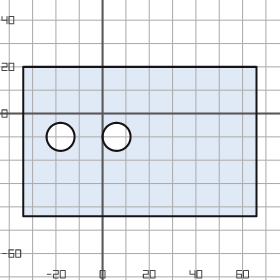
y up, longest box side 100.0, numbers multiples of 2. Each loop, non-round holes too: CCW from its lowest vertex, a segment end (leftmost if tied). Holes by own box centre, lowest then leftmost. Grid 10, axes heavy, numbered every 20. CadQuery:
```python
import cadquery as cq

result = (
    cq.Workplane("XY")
    .moveTo(-34.0, -44.0)
    .lineTo(66.0, -44.0)
    .lineTo(66.0, 20.0)
    .lineTo(-34.0, 20.0)
    .close()
    .moveTo(-18.0, -10.0)
    .circle(6.0)
    .moveTo(6.0, -10.0)
    .circle(6.0)
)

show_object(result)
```